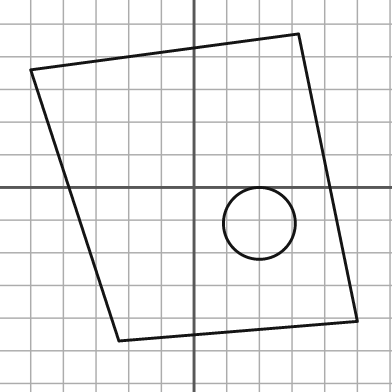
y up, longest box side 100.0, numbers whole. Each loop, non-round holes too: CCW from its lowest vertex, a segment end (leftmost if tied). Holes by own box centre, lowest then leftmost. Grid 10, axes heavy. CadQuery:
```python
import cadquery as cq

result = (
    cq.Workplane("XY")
    .moveTo(-23.0, -47.0)
    .lineTo(50.0, -41.0)
    .lineTo(32.0, 47.0)
    .lineTo(-50.0, 36.0)
    .close()
    .moveTo(20.0, -11.0)
    .circle(11.0)
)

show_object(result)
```